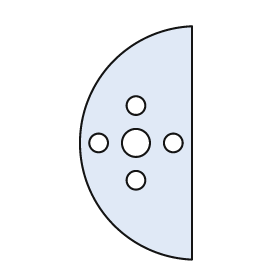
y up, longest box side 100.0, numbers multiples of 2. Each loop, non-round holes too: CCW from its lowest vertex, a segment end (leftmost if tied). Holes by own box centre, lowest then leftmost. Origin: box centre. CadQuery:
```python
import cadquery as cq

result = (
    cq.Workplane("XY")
    .moveTo(24.0, -50.0)
    .lineTo(24.0, 50.0)
    .threePointArc((-24.0, 0.0), (24.0, -50.0))
    .close()
    .moveTo(0.0, -16.0)
    .circle(4.0)
    .moveTo(-16.0, 0.0)
    .circle(4.0)
    .moveTo(0.0, 0.0)
    .circle(6.0)
    .moveTo(16.0, 0.0)
    .circle(4.0)
    .moveTo(0.0, 16.0)
    .circle(4.0)
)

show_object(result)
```